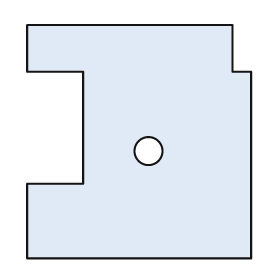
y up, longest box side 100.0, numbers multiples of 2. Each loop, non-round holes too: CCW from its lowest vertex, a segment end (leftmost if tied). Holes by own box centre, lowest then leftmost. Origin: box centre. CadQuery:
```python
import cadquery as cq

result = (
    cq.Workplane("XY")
    .moveTo(-48.0, -50.0)
    .lineTo(48.0, -50.0)
    .lineTo(48.0, 30.0)
    .lineTo(40.0, 30.0)
    .lineTo(40.0, 50.0)
    .lineTo(-48.0, 50.0)
    .lineTo(-48.0, 30.0)
    .lineTo(-24.0, 30.0)
    .lineTo(-24.0, -18.0)
    .lineTo(-48.0, -18.0)
    .close()
    .moveTo(4.0, -4.0)
    .circle(6.0)
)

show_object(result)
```